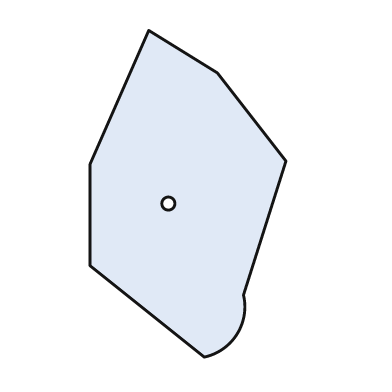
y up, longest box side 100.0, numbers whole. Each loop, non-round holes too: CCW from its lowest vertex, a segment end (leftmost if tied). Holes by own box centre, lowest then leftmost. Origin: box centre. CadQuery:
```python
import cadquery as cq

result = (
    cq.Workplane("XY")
    .moveTo(5.0, -50.0)
    .threePointArc((15.0, -43.0), (17.0, -31.0))
    .lineTo(30.0, 10.0)
    .lineTo(9.0, 37.0)
    .lineTo(-12.0, 50.0)
    .lineTo(-30.0, 9.0)
    .lineTo(-30.0, -22.0)
    .close()
    .moveTo(-6.0, -3.0)
    .circle(2.0)
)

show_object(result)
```